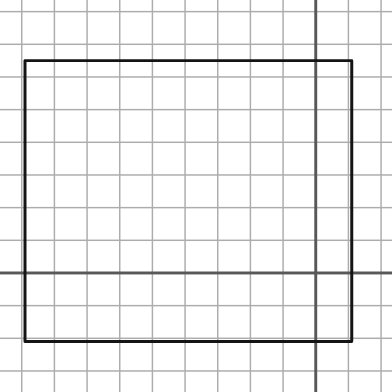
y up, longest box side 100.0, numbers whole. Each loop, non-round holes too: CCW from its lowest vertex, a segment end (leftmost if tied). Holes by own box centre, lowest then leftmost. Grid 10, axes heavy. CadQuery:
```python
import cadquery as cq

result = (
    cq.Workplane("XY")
    .moveTo(-89.0, -21.0)
    .lineTo(11.0, -21.0)
    .lineTo(11.0, 65.0)
    .lineTo(-89.0, 65.0)
    .close()
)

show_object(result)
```